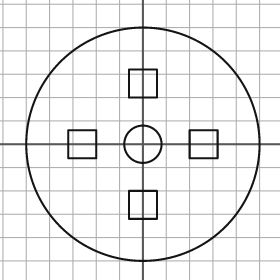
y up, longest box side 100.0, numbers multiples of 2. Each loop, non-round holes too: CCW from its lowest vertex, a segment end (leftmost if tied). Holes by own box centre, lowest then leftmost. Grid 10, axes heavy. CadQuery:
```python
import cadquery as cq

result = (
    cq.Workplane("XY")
    .moveTo(0.0, 0.0)
    .circle(50.0)
    .moveTo(-6.0, -32.0)
    .lineTo(6.0, -32.0)
    .lineTo(6.0, -20.0)
    .lineTo(-6.0, -20.0)
    .close()
    .moveTo(-32.0, -6.0)
    .lineTo(-20.0, -6.0)
    .lineTo(-20.0, 6.0)
    .lineTo(-32.0, 6.0)
    .close()
    .moveTo(0.0, 0.0)
    .circle(8.0)
    .moveTo(20.0, -6.0)
    .lineTo(32.0, -6.0)
    .lineTo(32.0, 6.0)
    .lineTo(20.0, 6.0)
    .close()
    .moveTo(-6.0, 20.0)
    .lineTo(6.0, 20.0)
    .lineTo(6.0, 32.0)
    .lineTo(-6.0, 32.0)
    .close()
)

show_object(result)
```